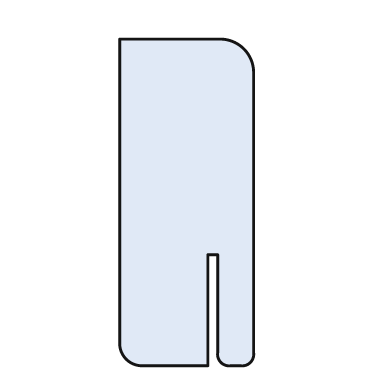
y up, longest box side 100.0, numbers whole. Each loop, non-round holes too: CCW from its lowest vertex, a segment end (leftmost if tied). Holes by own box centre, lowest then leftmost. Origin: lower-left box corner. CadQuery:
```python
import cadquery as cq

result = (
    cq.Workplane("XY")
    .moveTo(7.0, 0.0)
    .lineTo(27.0, 0.0)
    .lineTo(27.0, 34.0)
    .lineTo(30.0, 34.0)
    .lineTo(30.0, 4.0)
    .threePointArc((31.0, 1.0), (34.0, 0.0))
    .lineTo(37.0, 0.0)
    .threePointArc((40.0, 1.0), (41.0, 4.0))
    .lineTo(41.0, 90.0)
    .threePointArc((38.0, 97.0), (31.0, 100.0))
    .lineTo(0.0, 100.0)
    .lineTo(0.0, 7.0)
    .threePointArc((2.0, 2.0), (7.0, 0.0))
    .close()
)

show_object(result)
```